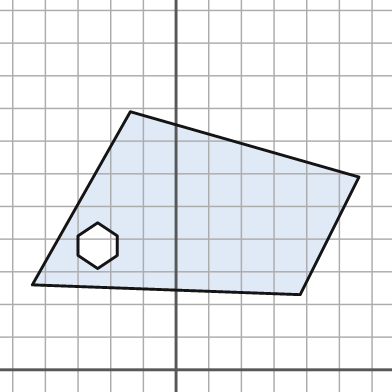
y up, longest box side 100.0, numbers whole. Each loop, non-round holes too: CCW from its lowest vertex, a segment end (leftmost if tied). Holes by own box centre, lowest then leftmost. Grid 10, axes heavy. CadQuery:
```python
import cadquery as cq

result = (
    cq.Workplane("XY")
    .moveTo(38.0, 23.0)
    .lineTo(56.0, 59.0)
    .lineTo(-14.0, 79.0)
    .lineTo(-44.0, 26.0)
    .close()
    .moveTo(-24.0, 31.0)
    .lineTo(-18.0, 35.0)
    .lineTo(-18.0, 41.0)
    .lineTo(-24.0, 45.0)
    .lineTo(-30.0, 41.0)
    .lineTo(-30.0, 35.0)
    .close()
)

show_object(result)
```